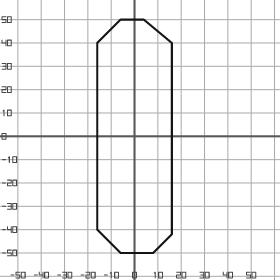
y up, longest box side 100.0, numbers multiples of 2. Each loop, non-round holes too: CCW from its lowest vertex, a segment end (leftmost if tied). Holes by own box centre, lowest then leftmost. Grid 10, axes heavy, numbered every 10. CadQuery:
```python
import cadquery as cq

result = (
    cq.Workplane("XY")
    .moveTo(-6.0, -50.0)
    .lineTo(8.0, -50.0)
    .lineTo(16.0, -42.0)
    .lineTo(16.0, 40.0)
    .lineTo(4.0, 50.0)
    .lineTo(-6.0, 50.0)
    .lineTo(-16.0, 40.0)
    .lineTo(-16.0, -40.0)
    .close()
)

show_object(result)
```